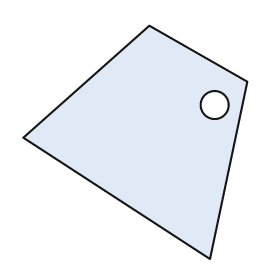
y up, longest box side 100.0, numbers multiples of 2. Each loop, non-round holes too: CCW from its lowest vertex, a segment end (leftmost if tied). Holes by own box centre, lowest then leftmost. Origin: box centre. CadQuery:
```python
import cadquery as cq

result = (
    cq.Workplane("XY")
    .moveTo(32.0, -50.0)
    .lineTo(48.0, 26.0)
    .lineTo(6.0, 50.0)
    .lineTo(-48.0, 2.0)
    .close()
    .moveTo(34.0, 16.0)
    .circle(6.0)
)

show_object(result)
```